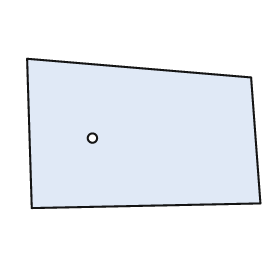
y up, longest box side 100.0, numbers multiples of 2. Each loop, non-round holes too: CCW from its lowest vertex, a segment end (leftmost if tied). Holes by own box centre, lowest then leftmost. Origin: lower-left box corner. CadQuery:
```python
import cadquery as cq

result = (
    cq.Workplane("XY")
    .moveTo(2.0, 0.0)
    .lineTo(100.0, 2.0)
    .lineTo(96.0, 56.0)
    .lineTo(0.0, 64.0)
    .close()
    .moveTo(28.0, 30.0)
    .circle(2.0)
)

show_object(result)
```